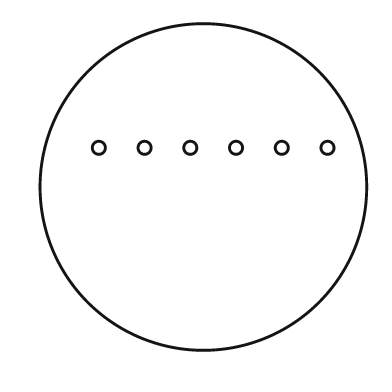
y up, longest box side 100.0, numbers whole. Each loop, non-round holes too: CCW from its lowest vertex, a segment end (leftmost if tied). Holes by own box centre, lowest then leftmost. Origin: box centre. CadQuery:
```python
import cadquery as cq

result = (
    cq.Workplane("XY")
    .moveTo(0.0, 0.0)
    .circle(50.0)
    .moveTo(-32.0, 12.0)
    .circle(2.0)
    .moveTo(-18.0, 12.0)
    .circle(2.0)
    .moveTo(-4.0, 12.0)
    .circle(2.0)
    .moveTo(10.0, 12.0)
    .circle(2.0)
    .moveTo(24.0, 12.0)
    .circle(2.0)
    .moveTo(38.0, 12.0)
    .circle(2.0)
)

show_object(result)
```